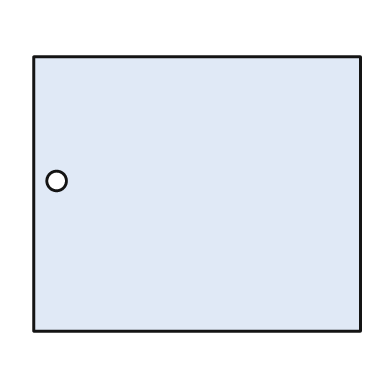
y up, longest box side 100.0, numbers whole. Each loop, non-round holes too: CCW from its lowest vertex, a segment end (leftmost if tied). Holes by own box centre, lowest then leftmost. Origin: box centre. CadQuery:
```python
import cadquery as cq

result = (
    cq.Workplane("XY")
    .moveTo(-50.0, -42.0)
    .lineTo(50.0, -42.0)
    .lineTo(50.0, 42.0)
    .lineTo(-50.0, 42.0)
    .close()
    .moveTo(-43.0, 4.0)
    .circle(3.0)
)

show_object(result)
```